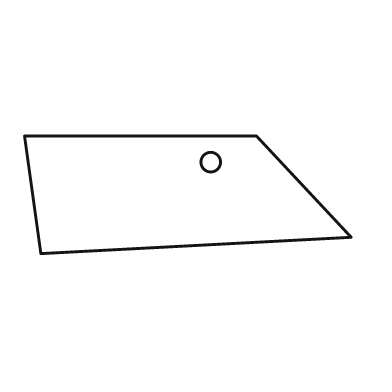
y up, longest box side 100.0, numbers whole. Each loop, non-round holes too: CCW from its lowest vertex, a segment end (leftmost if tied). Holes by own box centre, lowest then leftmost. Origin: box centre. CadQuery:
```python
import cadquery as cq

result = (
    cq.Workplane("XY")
    .moveTo(-45.0, -18.0)
    .lineTo(50.0, -13.0)
    .lineTo(21.0, 18.0)
    .lineTo(-50.0, 18.0)
    .close()
    .moveTo(7.0, 10.0)
    .circle(3.0)
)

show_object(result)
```